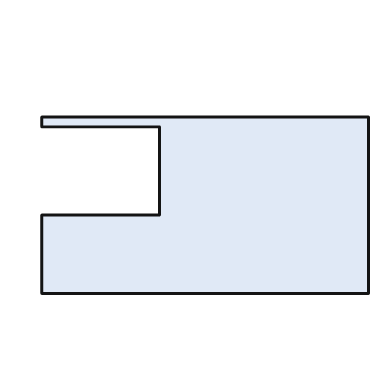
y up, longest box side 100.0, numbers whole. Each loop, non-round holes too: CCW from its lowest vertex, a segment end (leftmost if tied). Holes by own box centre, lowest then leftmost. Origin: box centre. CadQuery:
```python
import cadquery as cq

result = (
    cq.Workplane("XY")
    .moveTo(-50.0, -27.0)
    .lineTo(50.0, -27.0)
    .lineTo(50.0, 27.0)
    .lineTo(-50.0, 27.0)
    .lineTo(-50.0, 24.0)
    .lineTo(-14.0, 24.0)
    .lineTo(-14.0, -3.0)
    .lineTo(-50.0, -3.0)
    .close()
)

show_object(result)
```